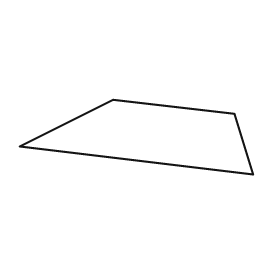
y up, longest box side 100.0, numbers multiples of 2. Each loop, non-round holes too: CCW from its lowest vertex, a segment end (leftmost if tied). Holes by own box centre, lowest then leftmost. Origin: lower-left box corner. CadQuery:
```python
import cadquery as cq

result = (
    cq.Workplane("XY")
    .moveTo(100.0, 0.0)
    .lineTo(92.0, 26.0)
    .lineTo(40.0, 32.0)
    .lineTo(0.0, 12.0)
    .close()
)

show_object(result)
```